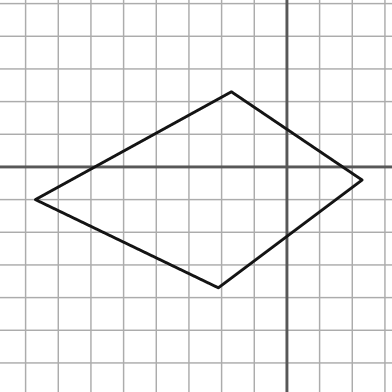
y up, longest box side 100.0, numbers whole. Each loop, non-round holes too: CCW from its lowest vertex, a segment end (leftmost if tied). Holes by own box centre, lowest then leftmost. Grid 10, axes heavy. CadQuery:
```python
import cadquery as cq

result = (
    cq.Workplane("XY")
    .moveTo(-21.0, -37.0)
    .lineTo(23.0, -4.0)
    .lineTo(-17.0, 23.0)
    .lineTo(-77.0, -10.0)
    .close()
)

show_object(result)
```